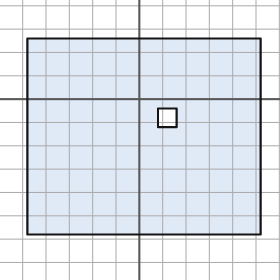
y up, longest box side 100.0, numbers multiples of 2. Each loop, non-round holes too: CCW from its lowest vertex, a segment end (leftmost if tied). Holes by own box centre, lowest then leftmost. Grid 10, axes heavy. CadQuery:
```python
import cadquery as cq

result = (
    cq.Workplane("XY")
    .moveTo(-48.0, -58.0)
    .lineTo(52.0, -58.0)
    .lineTo(52.0, 26.0)
    .lineTo(-48.0, 26.0)
    .close()
    .moveTo(8.0, -12.0)
    .lineTo(16.0, -12.0)
    .lineTo(16.0, -4.0)
    .lineTo(8.0, -4.0)
    .close()
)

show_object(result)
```